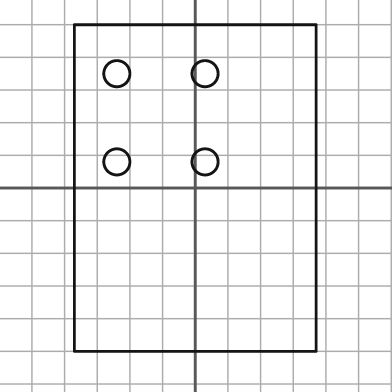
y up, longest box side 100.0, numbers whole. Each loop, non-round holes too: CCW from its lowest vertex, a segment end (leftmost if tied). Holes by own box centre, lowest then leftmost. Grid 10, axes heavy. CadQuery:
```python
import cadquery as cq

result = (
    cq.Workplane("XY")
    .moveTo(-37.0, -50.0)
    .lineTo(37.0, -50.0)
    .lineTo(37.0, 50.0)
    .lineTo(-37.0, 50.0)
    .close()
    .moveTo(-24.0, 8.0)
    .circle(4.0)
    .moveTo(3.0, 8.0)
    .circle(4.0)
    .moveTo(-24.0, 35.0)
    .circle(4.0)
    .moveTo(3.0, 35.0)
    .circle(4.0)
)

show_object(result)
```